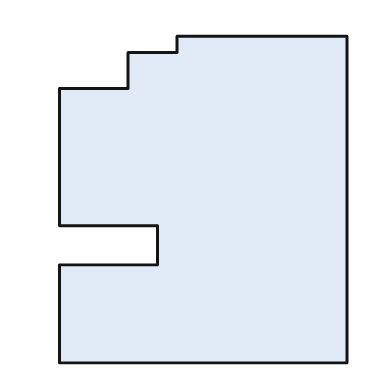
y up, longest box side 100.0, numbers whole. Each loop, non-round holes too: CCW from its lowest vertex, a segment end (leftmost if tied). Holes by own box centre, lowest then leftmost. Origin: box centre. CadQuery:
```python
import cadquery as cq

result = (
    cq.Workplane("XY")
    .moveTo(-44.0, -50.0)
    .lineTo(44.0, -50.0)
    .lineTo(44.0, 50.0)
    .lineTo(-8.0, 50.0)
    .lineTo(-8.0, 45.0)
    .lineTo(-23.0, 45.0)
    .lineTo(-23.0, 34.0)
    .lineTo(-44.0, 34.0)
    .lineTo(-44.0, -8.0)
    .lineTo(-14.0, -8.0)
    .lineTo(-14.0, -20.0)
    .lineTo(-44.0, -20.0)
    .close()
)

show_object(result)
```